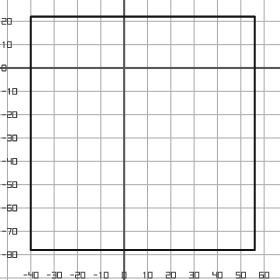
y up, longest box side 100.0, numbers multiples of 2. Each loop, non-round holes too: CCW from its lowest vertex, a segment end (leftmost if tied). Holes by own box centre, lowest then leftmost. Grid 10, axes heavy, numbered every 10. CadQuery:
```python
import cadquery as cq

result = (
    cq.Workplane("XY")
    .moveTo(-40.0, -78.0)
    .lineTo(56.0, -78.0)
    .lineTo(56.0, 22.0)
    .lineTo(-40.0, 22.0)
    .close()
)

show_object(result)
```